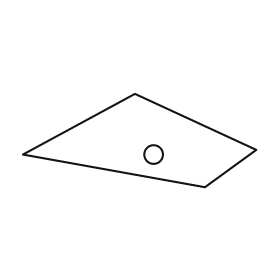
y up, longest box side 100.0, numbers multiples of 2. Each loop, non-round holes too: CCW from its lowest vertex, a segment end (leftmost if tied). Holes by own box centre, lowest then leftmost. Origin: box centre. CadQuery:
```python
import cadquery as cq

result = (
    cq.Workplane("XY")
    .moveTo(28.0, -20.0)
    .lineTo(50.0, -4.0)
    .lineTo(-2.0, 20.0)
    .lineTo(-50.0, -6.0)
    .close()
    .moveTo(6.0, -6.0)
    .circle(4.0)
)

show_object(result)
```